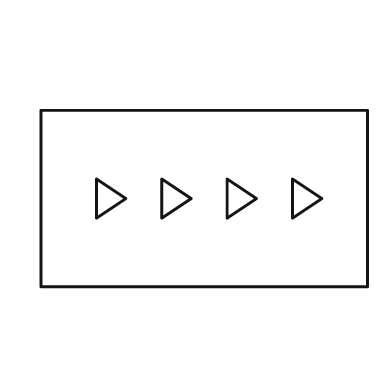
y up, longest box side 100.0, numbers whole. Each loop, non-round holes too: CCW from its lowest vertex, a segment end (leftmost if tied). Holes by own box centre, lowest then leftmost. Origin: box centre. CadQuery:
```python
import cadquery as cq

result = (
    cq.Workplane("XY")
    .moveTo(-50.0, -27.0)
    .lineTo(50.0, -27.0)
    .lineTo(50.0, 27.0)
    .lineTo(-50.0, 27.0)
    .close()
    .moveTo(-33.0, -6.0)
    .lineTo(-24.0, 0.0)
    .lineTo(-33.0, 6.0)
    .close()
    .moveTo(-13.0, -6.0)
    .lineTo(-4.0, 0.0)
    .lineTo(-13.0, 6.0)
    .close()
    .moveTo(7.0, -6.0)
    .lineTo(16.0, 0.0)
    .lineTo(7.0, 6.0)
    .close()
    .moveTo(27.0, -6.0)
    .lineTo(36.0, 0.0)
    .lineTo(27.0, 6.0)
    .close()
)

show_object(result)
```